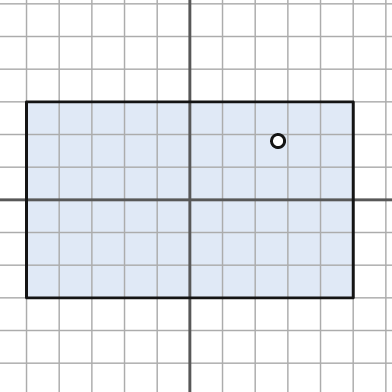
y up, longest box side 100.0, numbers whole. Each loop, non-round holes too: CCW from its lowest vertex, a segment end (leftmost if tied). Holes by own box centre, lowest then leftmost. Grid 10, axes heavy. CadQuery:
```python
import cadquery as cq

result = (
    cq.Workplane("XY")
    .moveTo(-50.0, -30.0)
    .lineTo(50.0, -30.0)
    .lineTo(50.0, 30.0)
    .lineTo(-50.0, 30.0)
    .close()
    .moveTo(27.0, 18.0)
    .circle(2.0)
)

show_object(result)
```